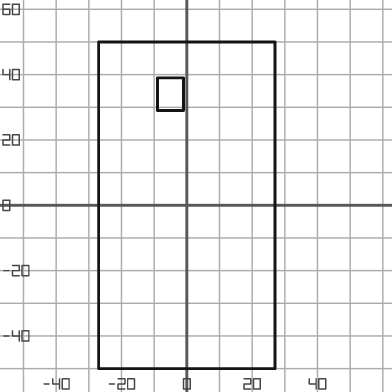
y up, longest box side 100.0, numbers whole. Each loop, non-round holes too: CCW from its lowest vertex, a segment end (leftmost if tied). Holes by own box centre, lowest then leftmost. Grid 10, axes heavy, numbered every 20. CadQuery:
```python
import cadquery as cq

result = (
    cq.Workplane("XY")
    .moveTo(-27.0, -50.0)
    .lineTo(27.0, -50.0)
    .lineTo(27.0, 50.0)
    .lineTo(-27.0, 50.0)
    .close()
    .moveTo(-9.0, 29.0)
    .lineTo(-1.0, 29.0)
    .lineTo(-1.0, 39.0)
    .lineTo(-9.0, 39.0)
    .close()
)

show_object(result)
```